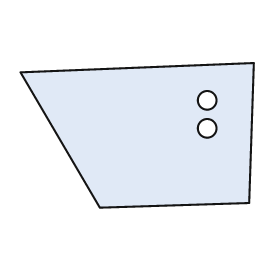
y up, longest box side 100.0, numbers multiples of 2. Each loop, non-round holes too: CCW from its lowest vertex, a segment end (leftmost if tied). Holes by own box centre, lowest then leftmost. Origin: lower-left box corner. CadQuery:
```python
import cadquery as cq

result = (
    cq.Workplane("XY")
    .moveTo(34.0, 0.0)
    .lineTo(98.0, 2.0)
    .lineTo(100.0, 62.0)
    .lineTo(0.0, 58.0)
    .close()
    .moveTo(80.0, 34.0)
    .circle(4.0)
    .moveTo(80.0, 46.0)
    .circle(4.0)
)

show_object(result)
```